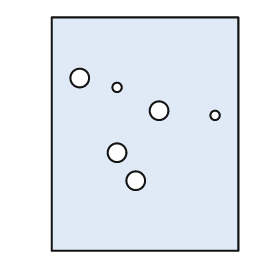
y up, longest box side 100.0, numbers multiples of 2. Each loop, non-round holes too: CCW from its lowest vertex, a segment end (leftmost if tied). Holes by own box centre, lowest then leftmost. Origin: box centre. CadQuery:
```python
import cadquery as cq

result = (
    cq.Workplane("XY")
    .moveTo(-40.0, -50.0)
    .lineTo(40.0, -50.0)
    .lineTo(40.0, 50.0)
    .lineTo(-40.0, 50.0)
    .close()
    .moveTo(-4.0, -20.0)
    .circle(4.0)
    .moveTo(-12.0, -8.0)
    .circle(4.0)
    .moveTo(30.0, 8.0)
    .circle(2.0)
    .moveTo(6.0, 10.0)
    .circle(4.0)
    .moveTo(-12.0, 20.0)
    .circle(2.0)
    .moveTo(-28.0, 24.0)
    .circle(4.0)
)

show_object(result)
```